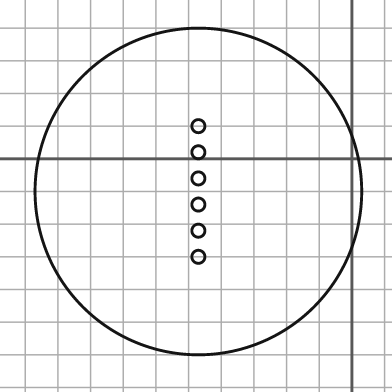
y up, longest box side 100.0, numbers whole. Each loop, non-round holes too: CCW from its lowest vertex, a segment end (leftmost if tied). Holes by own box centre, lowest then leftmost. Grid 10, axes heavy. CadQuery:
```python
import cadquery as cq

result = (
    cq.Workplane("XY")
    .moveTo(-47.0, -10.0)
    .circle(50.0)
    .moveTo(-47.0, -30.0)
    .circle(2.0)
    .moveTo(-47.0, -22.0)
    .circle(2.0)
    .moveTo(-47.0, -14.0)
    .circle(2.0)
    .moveTo(-47.0, -6.0)
    .circle(2.0)
    .moveTo(-47.0, 2.0)
    .circle(2.0)
    .moveTo(-47.0, 10.0)
    .circle(2.0)
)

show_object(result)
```